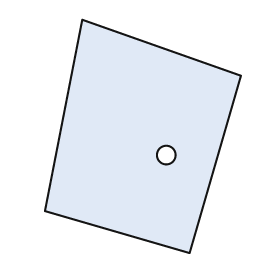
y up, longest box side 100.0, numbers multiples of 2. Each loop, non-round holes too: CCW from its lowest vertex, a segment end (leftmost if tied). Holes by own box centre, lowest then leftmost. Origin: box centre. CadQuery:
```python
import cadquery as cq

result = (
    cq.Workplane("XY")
    .moveTo(20.0, -50.0)
    .lineTo(42.0, 26.0)
    .lineTo(-26.0, 50.0)
    .lineTo(-42.0, -32.0)
    .close()
    .moveTo(10.0, -8.0)
    .circle(4.0)
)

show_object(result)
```